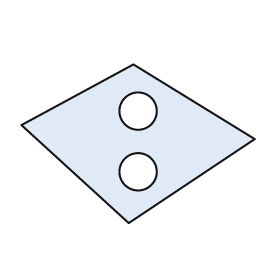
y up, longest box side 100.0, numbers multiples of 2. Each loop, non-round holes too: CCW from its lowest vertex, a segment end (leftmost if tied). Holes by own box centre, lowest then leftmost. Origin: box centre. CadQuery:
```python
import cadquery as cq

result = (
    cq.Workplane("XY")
    .moveTo(-4.0, -34.0)
    .lineTo(50.0, 2.0)
    .lineTo(-2.0, 34.0)
    .lineTo(-50.0, 8.0)
    .close()
    .moveTo(0.0, -12.0)
    .circle(8.0)
    .moveTo(0.0, 14.0)
    .circle(8.0)
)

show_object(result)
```